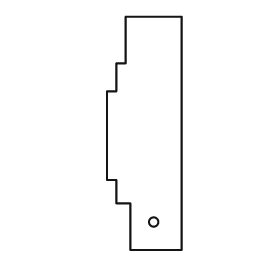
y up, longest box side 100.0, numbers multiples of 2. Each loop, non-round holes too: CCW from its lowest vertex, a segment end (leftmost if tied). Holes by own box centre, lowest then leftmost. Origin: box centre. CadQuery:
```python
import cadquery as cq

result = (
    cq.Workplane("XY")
    .moveTo(-6.0, -50.0)
    .lineTo(16.0, -50.0)
    .lineTo(16.0, 50.0)
    .lineTo(-8.0, 50.0)
    .lineTo(-8.0, 30.0)
    .lineTo(-12.0, 30.0)
    .lineTo(-12.0, 18.0)
    .lineTo(-16.0, 18.0)
    .lineTo(-16.0, -20.0)
    .lineTo(-12.0, -20.0)
    .lineTo(-12.0, -30.0)
    .lineTo(-6.0, -30.0)
    .close()
    .moveTo(4.0, -38.0)
    .circle(2.0)
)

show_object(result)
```